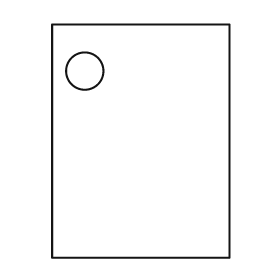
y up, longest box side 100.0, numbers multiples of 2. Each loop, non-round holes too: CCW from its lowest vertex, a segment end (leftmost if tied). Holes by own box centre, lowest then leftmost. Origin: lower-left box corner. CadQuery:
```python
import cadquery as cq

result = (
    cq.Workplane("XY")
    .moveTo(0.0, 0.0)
    .lineTo(76.0, 0.0)
    .lineTo(76.0, 100.0)
    .lineTo(0.0, 100.0)
    .close()
    .moveTo(14.0, 80.0)
    .circle(8.0)
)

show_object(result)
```